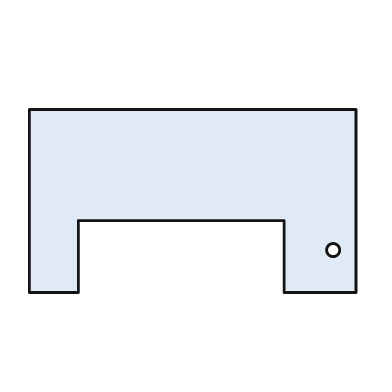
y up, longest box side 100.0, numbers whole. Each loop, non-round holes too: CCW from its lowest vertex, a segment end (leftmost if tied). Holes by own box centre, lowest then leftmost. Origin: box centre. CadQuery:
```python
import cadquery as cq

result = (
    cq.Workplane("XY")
    .moveTo(-50.0, -28.0)
    .lineTo(-35.0, -28.0)
    .lineTo(-35.0, -6.0)
    .lineTo(28.0, -6.0)
    .lineTo(28.0, -28.0)
    .lineTo(50.0, -28.0)
    .lineTo(50.0, 28.0)
    .lineTo(-50.0, 28.0)
    .close()
    .moveTo(43.0, -15.0)
    .circle(2.0)
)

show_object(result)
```